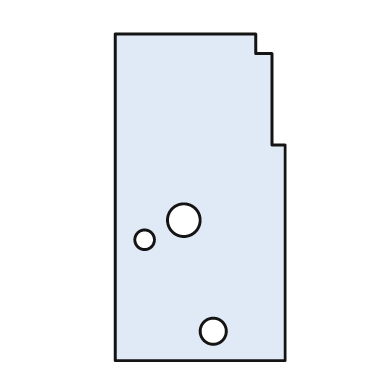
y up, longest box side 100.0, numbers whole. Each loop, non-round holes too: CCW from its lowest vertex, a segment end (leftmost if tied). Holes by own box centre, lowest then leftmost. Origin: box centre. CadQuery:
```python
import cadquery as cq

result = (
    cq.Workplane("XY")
    .moveTo(-26.0, -50.0)
    .lineTo(26.0, -50.0)
    .lineTo(26.0, 16.0)
    .lineTo(22.0, 16.0)
    .lineTo(22.0, 44.0)
    .lineTo(17.0, 44.0)
    .lineTo(17.0, 50.0)
    .lineTo(-26.0, 50.0)
    .close()
    .moveTo(4.0, -41.0)
    .circle(4.0)
    .moveTo(-17.0, -13.0)
    .circle(3.0)
    .moveTo(-5.0, -7.0)
    .circle(5.0)
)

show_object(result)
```